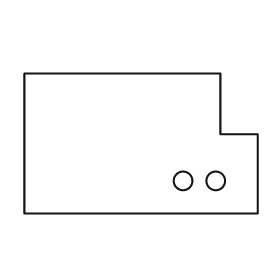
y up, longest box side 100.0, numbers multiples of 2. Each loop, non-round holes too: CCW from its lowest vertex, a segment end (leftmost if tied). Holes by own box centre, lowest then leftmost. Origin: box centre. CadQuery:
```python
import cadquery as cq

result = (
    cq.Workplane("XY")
    .moveTo(-50.0, -30.0)
    .lineTo(50.0, -30.0)
    .lineTo(50.0, 4.0)
    .lineTo(34.0, 4.0)
    .lineTo(34.0, 30.0)
    .lineTo(-50.0, 30.0)
    .close()
    .moveTo(18.0, -16.0)
    .circle(4.0)
    .moveTo(32.0, -16.0)
    .circle(4.0)
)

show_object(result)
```